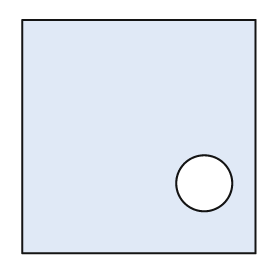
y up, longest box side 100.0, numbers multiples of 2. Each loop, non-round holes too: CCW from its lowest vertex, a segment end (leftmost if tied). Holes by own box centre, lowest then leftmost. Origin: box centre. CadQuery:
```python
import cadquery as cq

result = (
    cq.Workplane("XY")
    .moveTo(-50.0, -50.0)
    .lineTo(50.0, -50.0)
    .lineTo(50.0, 50.0)
    .lineTo(-50.0, 50.0)
    .close()
    .moveTo(28.0, -20.0)
    .circle(12.0)
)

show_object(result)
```